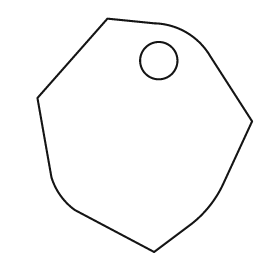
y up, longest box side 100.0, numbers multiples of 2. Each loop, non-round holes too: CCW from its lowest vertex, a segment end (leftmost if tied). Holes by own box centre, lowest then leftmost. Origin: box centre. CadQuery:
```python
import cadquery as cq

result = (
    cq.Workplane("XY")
    .moveTo(4.0, -50.0)
    .lineTo(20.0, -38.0)
    .threePointArc((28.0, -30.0), (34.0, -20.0))
    .lineTo(46.0, 6.0)
    .lineTo(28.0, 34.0)
    .threePointArc((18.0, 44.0), (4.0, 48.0))
    .lineTo(-16.0, 50.0)
    .lineTo(-46.0, 16.0)
    .lineTo(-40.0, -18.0)
    .threePointArc((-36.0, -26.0), (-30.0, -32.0))
    .close()
    .moveTo(6.0, 32.0)
    .circle(8.0)
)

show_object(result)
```